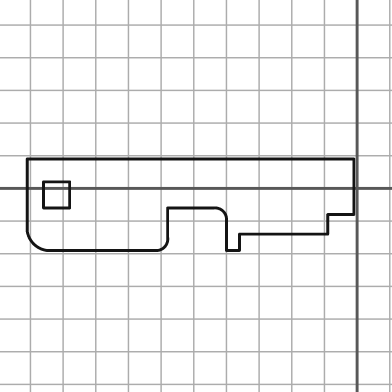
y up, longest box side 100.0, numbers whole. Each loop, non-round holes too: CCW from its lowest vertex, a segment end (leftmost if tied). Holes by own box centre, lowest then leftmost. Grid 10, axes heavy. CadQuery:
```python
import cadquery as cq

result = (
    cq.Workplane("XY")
    .moveTo(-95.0, -19.0)
    .lineTo(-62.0, -19.0)
    .threePointArc((-59.0, -18.0), (-58.0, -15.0))
    .lineTo(-58.0, -6.0)
    .lineTo(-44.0, -6.0)
    .threePointArc((-41.0, -7.0), (-40.0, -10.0))
    .lineTo(-40.0, -19.0)
    .lineTo(-36.0, -19.0)
    .lineTo(-36.0, -14.0)
    .lineTo(-9.0, -14.0)
    .lineTo(-9.0, -8.0)
    .lineTo(-1.0, -8.0)
    .lineTo(-1.0, 9.0)
    .lineTo(-101.0, 9.0)
    .lineTo(-101.0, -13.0)
    .threePointArc((-99.0, -17.0), (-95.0, -19.0))
    .close()
    .moveTo(-96.0, -6.0)
    .lineTo(-88.0, -6.0)
    .lineTo(-88.0, 2.0)
    .lineTo(-96.0, 2.0)
    .close()
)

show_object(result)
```